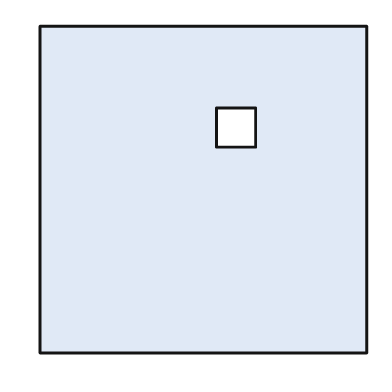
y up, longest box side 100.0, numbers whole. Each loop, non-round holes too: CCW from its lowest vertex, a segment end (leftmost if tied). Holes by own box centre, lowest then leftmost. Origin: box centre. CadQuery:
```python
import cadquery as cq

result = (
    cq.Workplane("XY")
    .moveTo(-50.0, -50.0)
    .lineTo(50.0, -50.0)
    .lineTo(50.0, 50.0)
    .lineTo(-50.0, 50.0)
    .close()
    .moveTo(4.0, 13.0)
    .lineTo(16.0, 13.0)
    .lineTo(16.0, 25.0)
    .lineTo(4.0, 25.0)
    .close()
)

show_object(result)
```